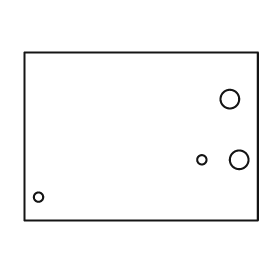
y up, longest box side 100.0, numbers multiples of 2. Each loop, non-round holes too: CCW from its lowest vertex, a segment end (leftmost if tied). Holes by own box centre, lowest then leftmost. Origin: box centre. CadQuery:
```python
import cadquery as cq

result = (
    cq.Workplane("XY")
    .moveTo(-50.0, -36.0)
    .lineTo(50.0, -36.0)
    .lineTo(50.0, 36.0)
    .lineTo(-50.0, 36.0)
    .close()
    .moveTo(-44.0, -26.0)
    .circle(2.0)
    .moveTo(26.0, -10.0)
    .circle(2.0)
    .moveTo(42.0, -10.0)
    .circle(4.0)
    .moveTo(38.0, 16.0)
    .circle(4.0)
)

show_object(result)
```